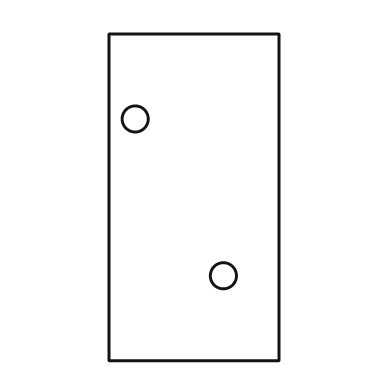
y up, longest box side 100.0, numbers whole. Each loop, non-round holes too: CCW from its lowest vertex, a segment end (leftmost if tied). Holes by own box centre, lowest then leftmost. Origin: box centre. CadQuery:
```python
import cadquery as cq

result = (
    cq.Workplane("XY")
    .moveTo(-26.0, -50.0)
    .lineTo(26.0, -50.0)
    .lineTo(26.0, 50.0)
    .lineTo(-26.0, 50.0)
    .close()
    .moveTo(9.0, -24.0)
    .circle(4.0)
    .moveTo(-18.0, 24.0)
    .circle(4.0)
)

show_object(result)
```